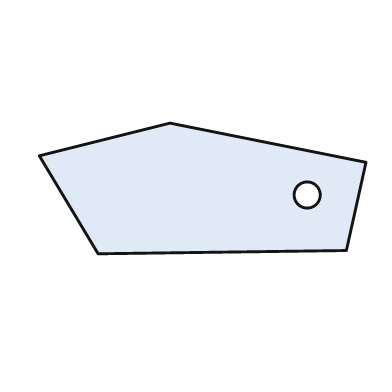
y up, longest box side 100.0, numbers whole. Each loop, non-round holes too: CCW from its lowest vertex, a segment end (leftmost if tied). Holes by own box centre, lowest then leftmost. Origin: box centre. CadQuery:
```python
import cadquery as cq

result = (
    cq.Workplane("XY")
    .moveTo(-32.0, -20.0)
    .lineTo(44.0, -19.0)
    .lineTo(50.0, 8.0)
    .lineTo(-10.0, 20.0)
    .lineTo(-50.0, 10.0)
    .close()
    .moveTo(32.0, -2.0)
    .circle(4.0)
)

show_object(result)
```